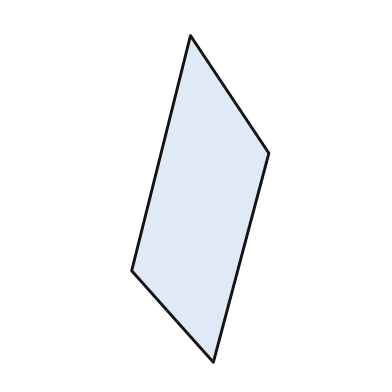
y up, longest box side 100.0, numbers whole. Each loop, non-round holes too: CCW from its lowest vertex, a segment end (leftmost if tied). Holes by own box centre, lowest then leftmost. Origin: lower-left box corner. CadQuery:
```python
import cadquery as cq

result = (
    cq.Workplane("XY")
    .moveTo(25.0, 0.0)
    .lineTo(42.0, 64.0)
    .lineTo(18.0, 100.0)
    .lineTo(0.0, 28.0)
    .close()
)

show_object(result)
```